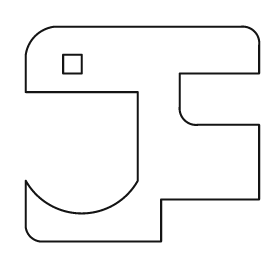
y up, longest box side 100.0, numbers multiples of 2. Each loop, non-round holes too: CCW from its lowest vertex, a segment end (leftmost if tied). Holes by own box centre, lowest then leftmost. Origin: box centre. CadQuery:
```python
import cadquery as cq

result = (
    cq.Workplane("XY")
    .moveTo(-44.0, -46.0)
    .lineTo(8.0, -46.0)
    .lineTo(8.0, -28.0)
    .lineTo(50.0, -28.0)
    .lineTo(50.0, 4.0)
    .lineTo(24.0, 4.0)
    .threePointArc((18.0, 6.0), (16.0, 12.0))
    .lineTo(16.0, 26.0)
    .lineTo(50.0, 26.0)
    .lineTo(50.0, 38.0)
    .threePointArc((48.0, 44.0), (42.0, 46.0))
    .lineTo(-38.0, 46.0)
    .threePointArc((-46.0, 42.0), (-50.0, 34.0))
    .lineTo(-50.0, 18.0)
    .lineTo(-2.0, 18.0)
    .lineTo(-2.0, -20.0)
    .threePointArc((-26.0, -34.0), (-50.0, -20.0))
    .lineTo(-50.0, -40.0)
    .threePointArc((-48.0, -44.0), (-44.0, -46.0))
    .close()
    .moveTo(-34.0, 26.0)
    .lineTo(-26.0, 26.0)
    .lineTo(-26.0, 34.0)
    .lineTo(-34.0, 34.0)
    .close()
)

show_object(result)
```